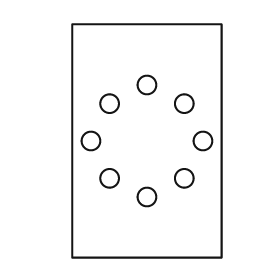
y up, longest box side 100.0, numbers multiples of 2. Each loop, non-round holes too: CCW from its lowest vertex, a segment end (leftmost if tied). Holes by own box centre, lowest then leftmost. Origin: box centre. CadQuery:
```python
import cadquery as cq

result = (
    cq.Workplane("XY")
    .moveTo(-32.0, -50.0)
    .lineTo(32.0, -50.0)
    .lineTo(32.0, 50.0)
    .lineTo(-32.0, 50.0)
    .close()
    .moveTo(0.0, -24.0)
    .circle(4.0)
    .moveTo(-16.0, -16.0)
    .circle(4.0)
    .moveTo(16.0, -16.0)
    .circle(4.0)
    .moveTo(-24.0, 0.0)
    .circle(4.0)
    .moveTo(24.0, 0.0)
    .circle(4.0)
    .moveTo(-16.0, 16.0)
    .circle(4.0)
    .moveTo(16.0, 16.0)
    .circle(4.0)
    .moveTo(0.0, 24.0)
    .circle(4.0)
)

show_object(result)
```